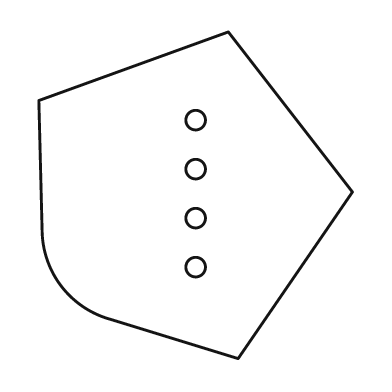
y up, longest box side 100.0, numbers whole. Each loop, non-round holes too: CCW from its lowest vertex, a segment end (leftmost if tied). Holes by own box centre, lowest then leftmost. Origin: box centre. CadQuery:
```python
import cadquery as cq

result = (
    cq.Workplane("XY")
    .moveTo(13.0, -50.0)
    .lineTo(48.0, 1.0)
    .lineTo(10.0, 50.0)
    .lineTo(-48.0, 29.0)
    .lineTo(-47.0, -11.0)
    .threePointArc((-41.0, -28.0), (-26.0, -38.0))
    .close()
    .moveTo(0.0, -22.0)
    .circle(3.0)
    .moveTo(0.0, -7.0)
    .circle(3.0)
    .moveTo(0.0, 8.0)
    .circle(3.0)
    .moveTo(0.0, 23.0)
    .circle(3.0)
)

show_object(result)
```